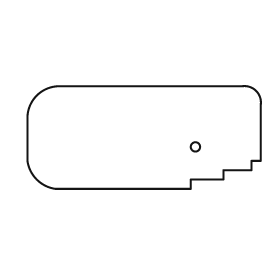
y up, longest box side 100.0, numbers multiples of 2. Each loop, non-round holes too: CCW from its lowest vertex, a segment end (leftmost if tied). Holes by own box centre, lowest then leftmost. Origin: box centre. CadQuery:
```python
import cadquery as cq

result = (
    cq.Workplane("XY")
    .moveTo(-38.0, -22.0)
    .lineTo(20.0, -22.0)
    .lineTo(20.0, -18.0)
    .lineTo(34.0, -18.0)
    .lineTo(34.0, -14.0)
    .lineTo(46.0, -14.0)
    .lineTo(46.0, -10.0)
    .lineTo(50.0, -10.0)
    .lineTo(50.0, 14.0)
    .threePointArc((48.0, 20.0), (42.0, 22.0))
    .lineTo(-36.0, 22.0)
    .threePointArc((-46.0, 18.0), (-50.0, 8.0))
    .lineTo(-50.0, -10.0)
    .threePointArc((-46.0, -18.0), (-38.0, -22.0))
    .close()
    .moveTo(22.0, -4.0)
    .circle(2.0)
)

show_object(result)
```